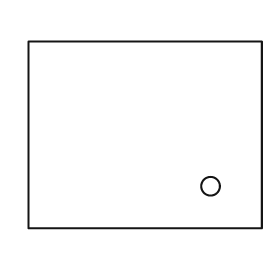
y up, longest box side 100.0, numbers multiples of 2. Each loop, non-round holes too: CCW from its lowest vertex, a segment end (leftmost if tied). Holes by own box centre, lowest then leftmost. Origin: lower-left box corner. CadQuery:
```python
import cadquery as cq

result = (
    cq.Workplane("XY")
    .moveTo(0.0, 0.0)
    .lineTo(100.0, 0.0)
    .lineTo(100.0, 80.0)
    .lineTo(0.0, 80.0)
    .close()
    .moveTo(78.0, 18.0)
    .circle(4.0)
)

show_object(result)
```